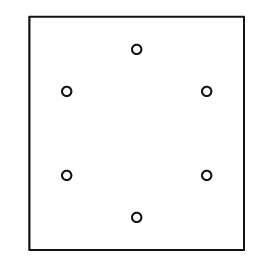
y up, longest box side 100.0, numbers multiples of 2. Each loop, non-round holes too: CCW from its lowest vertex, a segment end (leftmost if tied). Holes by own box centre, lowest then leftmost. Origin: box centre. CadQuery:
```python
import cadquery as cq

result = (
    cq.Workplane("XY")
    .moveTo(-46.0, -50.0)
    .lineTo(46.0, -50.0)
    .lineTo(46.0, 50.0)
    .lineTo(-46.0, 50.0)
    .close()
    .moveTo(0.0, -36.0)
    .circle(2.0)
    .moveTo(-30.0, -18.0)
    .circle(2.0)
    .moveTo(30.0, -18.0)
    .circle(2.0)
    .moveTo(-30.0, 18.0)
    .circle(2.0)
    .moveTo(30.0, 18.0)
    .circle(2.0)
    .moveTo(0.0, 36.0)
    .circle(2.0)
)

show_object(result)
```